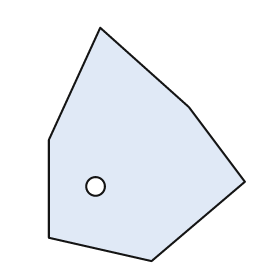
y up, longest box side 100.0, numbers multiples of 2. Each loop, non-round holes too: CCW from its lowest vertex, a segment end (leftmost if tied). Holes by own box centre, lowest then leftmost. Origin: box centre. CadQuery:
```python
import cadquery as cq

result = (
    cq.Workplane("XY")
    .moveTo(2.0, -50.0)
    .lineTo(42.0, -16.0)
    .lineTo(18.0, 16.0)
    .lineTo(-20.0, 50.0)
    .lineTo(-42.0, 2.0)
    .lineTo(-42.0, -40.0)
    .close()
    .moveTo(-22.0, -18.0)
    .circle(4.0)
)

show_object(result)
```